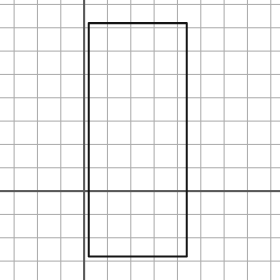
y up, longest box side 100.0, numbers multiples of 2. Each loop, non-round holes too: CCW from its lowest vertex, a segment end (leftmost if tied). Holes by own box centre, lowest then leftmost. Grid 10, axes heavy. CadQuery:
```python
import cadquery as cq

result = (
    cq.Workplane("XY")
    .moveTo(2.0, -28.0)
    .lineTo(44.0, -28.0)
    .lineTo(44.0, 72.0)
    .lineTo(2.0, 72.0)
    .close()
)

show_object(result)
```